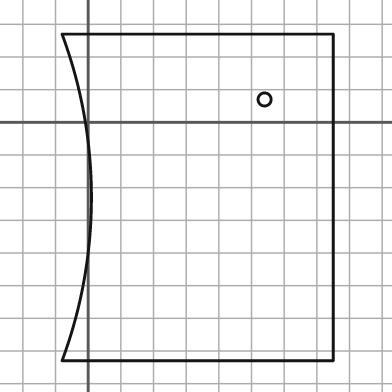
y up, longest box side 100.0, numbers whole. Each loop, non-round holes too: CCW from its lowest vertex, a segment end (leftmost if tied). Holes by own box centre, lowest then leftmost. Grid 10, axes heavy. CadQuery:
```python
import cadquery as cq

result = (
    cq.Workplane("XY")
    .moveTo(-8.0, -73.0)
    .lineTo(75.0, -73.0)
    .lineTo(75.0, 27.0)
    .lineTo(-8.0, 27.0)
    .threePointArc((1.0, -23.0), (-8.0, -73.0))
    .close()
    .moveTo(54.0, 7.0)
    .circle(2.0)
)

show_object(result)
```